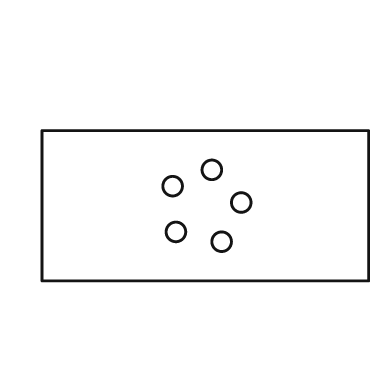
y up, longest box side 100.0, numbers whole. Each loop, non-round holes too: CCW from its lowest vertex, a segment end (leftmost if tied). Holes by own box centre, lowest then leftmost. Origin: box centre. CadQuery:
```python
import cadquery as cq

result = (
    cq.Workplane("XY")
    .moveTo(-50.0, -23.0)
    .lineTo(50.0, -23.0)
    .lineTo(50.0, 23.0)
    .lineTo(-50.0, 23.0)
    .close()
    .moveTo(5.0, -11.0)
    .circle(3.0)
    .moveTo(-9.0, -8.0)
    .circle(3.0)
    .moveTo(11.0, 1.0)
    .circle(3.0)
    .moveTo(-10.0, 6.0)
    .circle(3.0)
    .moveTo(2.0, 11.0)
    .circle(3.0)
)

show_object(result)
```